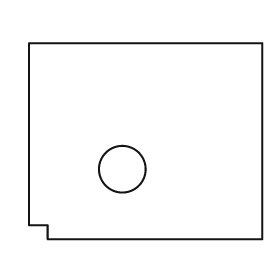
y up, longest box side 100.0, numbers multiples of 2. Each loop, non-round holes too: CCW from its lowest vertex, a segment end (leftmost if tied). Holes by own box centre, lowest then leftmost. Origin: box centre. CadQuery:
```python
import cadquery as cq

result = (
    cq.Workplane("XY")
    .moveTo(-42.0, -42.0)
    .lineTo(50.0, -42.0)
    .lineTo(50.0, 42.0)
    .lineTo(-50.0, 42.0)
    .lineTo(-50.0, -36.0)
    .lineTo(-42.0, -36.0)
    .close()
    .moveTo(-10.0, -12.0)
    .circle(10.0)
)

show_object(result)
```